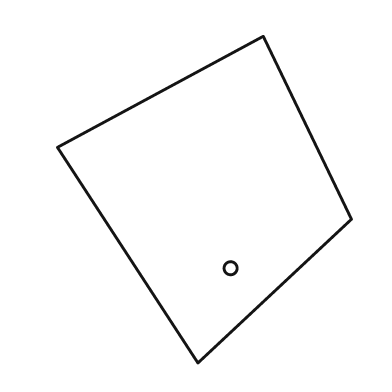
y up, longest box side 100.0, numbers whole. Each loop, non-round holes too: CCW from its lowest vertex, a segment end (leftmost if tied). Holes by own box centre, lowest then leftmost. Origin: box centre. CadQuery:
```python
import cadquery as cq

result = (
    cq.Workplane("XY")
    .moveTo(-2.0, -50.0)
    .lineTo(45.0, -6.0)
    .lineTo(18.0, 50.0)
    .lineTo(-45.0, 16.0)
    .close()
    .moveTo(8.0, -21.0)
    .circle(2.0)
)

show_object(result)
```